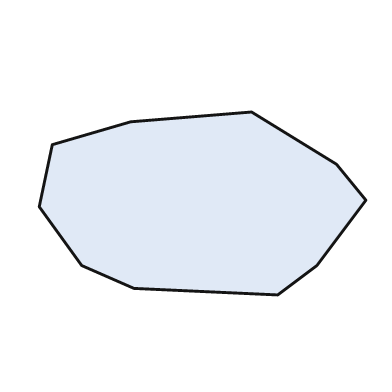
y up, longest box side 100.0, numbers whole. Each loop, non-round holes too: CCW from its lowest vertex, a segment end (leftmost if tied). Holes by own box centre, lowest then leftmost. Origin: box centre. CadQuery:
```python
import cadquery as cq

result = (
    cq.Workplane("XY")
    .moveTo(23.0, -28.0)
    .lineTo(35.0, -19.0)
    .lineTo(50.0, 1.0)
    .lineTo(41.0, 12.0)
    .lineTo(15.0, 28.0)
    .lineTo(-22.0, 25.0)
    .lineTo(-46.0, 18.0)
    .lineTo(-50.0, -1.0)
    .lineTo(-37.0, -19.0)
    .lineTo(-21.0, -26.0)
    .close()
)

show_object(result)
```